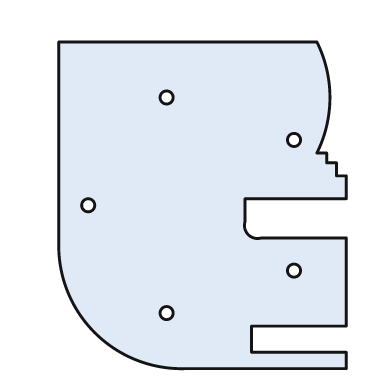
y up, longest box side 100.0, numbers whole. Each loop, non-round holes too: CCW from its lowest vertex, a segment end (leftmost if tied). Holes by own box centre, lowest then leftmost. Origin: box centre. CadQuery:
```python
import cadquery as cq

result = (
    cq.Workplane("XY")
    .moveTo(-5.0, -50.0)
    .lineTo(44.0, -50.0)
    .lineTo(44.0, -45.0)
    .lineTo(15.0, -45.0)
    .lineTo(15.0, -37.0)
    .lineTo(44.0, -37.0)
    .lineTo(44.0, -10.0)
    .lineTo(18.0, -10.0)
    .threePointArc((14.0, -9.0), (13.0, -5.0))
    .lineTo(13.0, 2.0)
    .lineTo(44.0, 2.0)
    .lineTo(44.0, 9.0)
    .lineTo(41.0, 9.0)
    .lineTo(41.0, 13.0)
    .lineTo(38.0, 13.0)
    .lineTo(38.0, 16.0)
    .lineTo(35.0, 16.0)
    .threePointArc((39.0, 33.0), (35.0, 50.0))
    .lineTo(-44.0, 50.0)
    .lineTo(-44.0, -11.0)
    .threePointArc((-33.0, -39.0), (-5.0, -50.0))
    .close()
    .moveTo(-11.0, -33.0)
    .circle(2.0)
    .moveTo(28.0, -20.0)
    .circle(2.0)
    .moveTo(-35.0, 0.0)
    .circle(2.0)
    .moveTo(28.0, 20.0)
    .circle(2.0)
    .moveTo(-11.0, 33.0)
    .circle(2.0)
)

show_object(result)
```